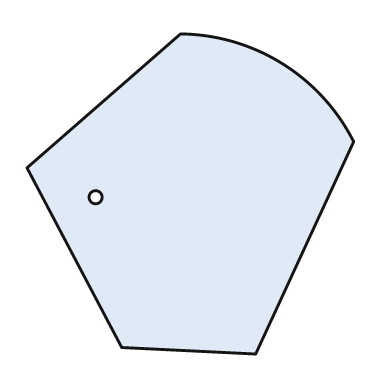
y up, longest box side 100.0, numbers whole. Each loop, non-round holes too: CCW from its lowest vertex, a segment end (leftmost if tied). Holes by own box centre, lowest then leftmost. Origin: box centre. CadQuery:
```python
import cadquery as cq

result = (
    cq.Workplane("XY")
    .moveTo(20.0, -49.0)
    .lineTo(50.0, 16.0)
    .threePointArc((28.0, 40.0), (-3.0, 49.0))
    .lineTo(-50.0, 8.0)
    .lineTo(-21.0, -47.0)
    .close()
    .moveTo(-29.0, -1.0)
    .circle(2.0)
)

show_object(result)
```